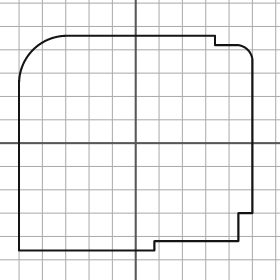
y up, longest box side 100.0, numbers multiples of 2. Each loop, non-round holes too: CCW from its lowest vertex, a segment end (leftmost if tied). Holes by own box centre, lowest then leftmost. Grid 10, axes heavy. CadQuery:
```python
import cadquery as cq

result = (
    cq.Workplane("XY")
    .moveTo(-50.0, -46.0)
    .lineTo(8.0, -46.0)
    .lineTo(8.0, -42.0)
    .lineTo(44.0, -42.0)
    .lineTo(44.0, -30.0)
    .lineTo(50.0, -30.0)
    .lineTo(50.0, 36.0)
    .threePointArc((48.0, 40.0), (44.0, 42.0))
    .lineTo(34.0, 42.0)
    .lineTo(34.0, 46.0)
    .lineTo(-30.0, 46.0)
    .threePointArc((-44.0, 40.0), (-50.0, 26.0))
    .close()
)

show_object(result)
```